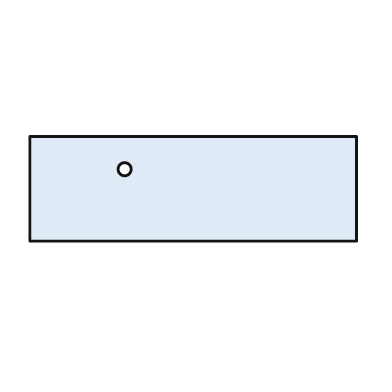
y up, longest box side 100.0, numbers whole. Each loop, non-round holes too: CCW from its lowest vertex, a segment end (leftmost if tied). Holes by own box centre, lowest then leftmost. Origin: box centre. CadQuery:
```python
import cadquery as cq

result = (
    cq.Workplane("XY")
    .moveTo(-50.0, -16.0)
    .lineTo(50.0, -16.0)
    .lineTo(50.0, 16.0)
    .lineTo(-50.0, 16.0)
    .close()
    .moveTo(-21.0, 6.0)
    .circle(2.0)
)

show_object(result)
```